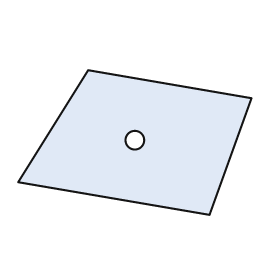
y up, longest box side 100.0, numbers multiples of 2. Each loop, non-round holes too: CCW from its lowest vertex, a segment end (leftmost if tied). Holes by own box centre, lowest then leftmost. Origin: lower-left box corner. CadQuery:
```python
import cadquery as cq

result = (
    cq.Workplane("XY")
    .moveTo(82.0, 0.0)
    .lineTo(100.0, 50.0)
    .lineTo(30.0, 62.0)
    .lineTo(0.0, 14.0)
    .close()
    .moveTo(50.0, 32.0)
    .circle(4.0)
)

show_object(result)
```